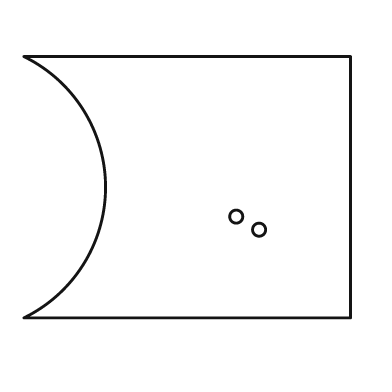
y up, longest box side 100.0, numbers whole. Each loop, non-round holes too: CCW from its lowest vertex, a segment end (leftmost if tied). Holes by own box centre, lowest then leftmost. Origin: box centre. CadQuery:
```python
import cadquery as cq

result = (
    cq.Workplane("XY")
    .moveTo(-50.0, -40.0)
    .lineTo(50.0, -40.0)
    .lineTo(50.0, 40.0)
    .lineTo(-50.0, 40.0)
    .threePointArc((-25.0, 0.0), (-50.0, -40.0))
    .close()
    .moveTo(22.0, -13.0)
    .circle(2.0)
    .moveTo(15.0, -9.0)
    .circle(2.0)
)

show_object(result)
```